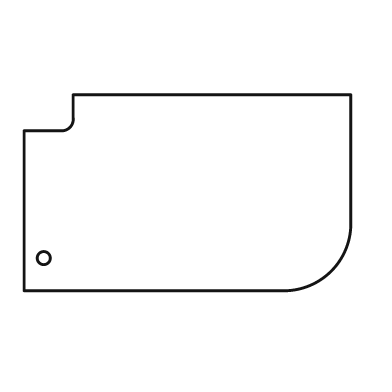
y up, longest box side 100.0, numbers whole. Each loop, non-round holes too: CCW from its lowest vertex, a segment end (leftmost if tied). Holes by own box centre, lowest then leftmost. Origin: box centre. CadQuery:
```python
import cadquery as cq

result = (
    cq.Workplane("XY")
    .moveTo(-50.0, -30.0)
    .lineTo(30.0, -30.0)
    .threePointArc((44.0, -24.0), (50.0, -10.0))
    .lineTo(50.0, 30.0)
    .lineTo(-35.0, 30.0)
    .lineTo(-35.0, 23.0)
    .threePointArc((-36.0, 20.0), (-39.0, 19.0))
    .lineTo(-50.0, 19.0)
    .close()
    .moveTo(-44.0, -20.0)
    .circle(2.0)
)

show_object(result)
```